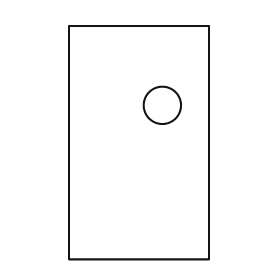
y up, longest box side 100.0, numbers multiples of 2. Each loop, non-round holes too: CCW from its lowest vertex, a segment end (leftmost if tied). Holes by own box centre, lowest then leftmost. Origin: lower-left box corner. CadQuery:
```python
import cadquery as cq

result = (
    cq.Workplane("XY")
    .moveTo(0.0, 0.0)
    .lineTo(60.0, 0.0)
    .lineTo(60.0, 100.0)
    .lineTo(0.0, 100.0)
    .close()
    .moveTo(40.0, 66.0)
    .circle(8.0)
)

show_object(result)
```